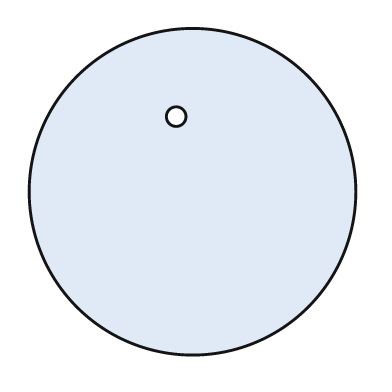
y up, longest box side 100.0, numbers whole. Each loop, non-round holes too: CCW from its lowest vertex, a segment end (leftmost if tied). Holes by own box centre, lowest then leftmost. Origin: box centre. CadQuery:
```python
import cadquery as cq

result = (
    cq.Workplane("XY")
    .moveTo(0.0, 0.0)
    .circle(50.0)
    .moveTo(-5.0, 23.0)
    .circle(3.0)
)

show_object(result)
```